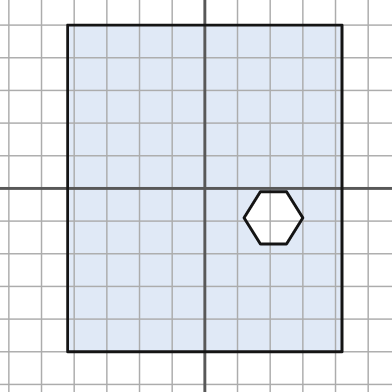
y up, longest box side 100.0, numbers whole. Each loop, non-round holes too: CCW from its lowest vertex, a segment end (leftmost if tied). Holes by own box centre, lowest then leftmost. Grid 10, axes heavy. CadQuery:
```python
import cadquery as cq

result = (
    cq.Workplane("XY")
    .moveTo(-42.0, -50.0)
    .lineTo(42.0, -50.0)
    .lineTo(42.0, 50.0)
    .lineTo(-42.0, 50.0)
    .close()
    .moveTo(17.0, -17.0)
    .lineTo(25.0, -17.0)
    .lineTo(30.0, -9.0)
    .lineTo(25.0, -1.0)
    .lineTo(17.0, -1.0)
    .lineTo(12.0, -9.0)
    .close()
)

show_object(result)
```